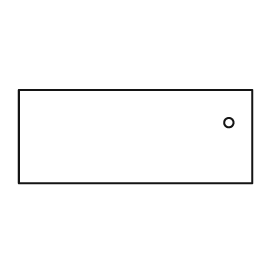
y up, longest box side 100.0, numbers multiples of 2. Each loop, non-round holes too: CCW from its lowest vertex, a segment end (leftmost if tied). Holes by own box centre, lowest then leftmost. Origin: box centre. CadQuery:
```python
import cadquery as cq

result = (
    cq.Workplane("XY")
    .moveTo(-50.0, -20.0)
    .lineTo(50.0, -20.0)
    .lineTo(50.0, 20.0)
    .lineTo(-50.0, 20.0)
    .close()
    .moveTo(40.0, 6.0)
    .circle(2.0)
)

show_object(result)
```